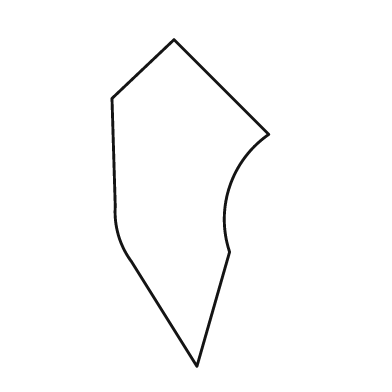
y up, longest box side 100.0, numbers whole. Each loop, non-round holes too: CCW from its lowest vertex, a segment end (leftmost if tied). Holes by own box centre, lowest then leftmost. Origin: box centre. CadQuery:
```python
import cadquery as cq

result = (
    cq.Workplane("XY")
    .moveTo(2.0, -50.0)
    .lineTo(12.0, -15.0)
    .threePointArc((12.0, 5.0), (24.0, 21.0))
    .lineTo(-5.0, 50.0)
    .lineTo(-24.0, 32.0)
    .lineTo(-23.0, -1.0)
    .threePointArc((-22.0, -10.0), (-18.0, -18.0))
    .close()
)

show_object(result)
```